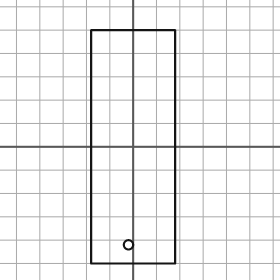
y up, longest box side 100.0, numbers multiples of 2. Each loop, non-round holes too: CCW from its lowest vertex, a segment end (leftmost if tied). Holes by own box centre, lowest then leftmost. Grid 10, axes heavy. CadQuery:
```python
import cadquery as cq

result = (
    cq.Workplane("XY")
    .moveTo(-18.0, -50.0)
    .lineTo(18.0, -50.0)
    .lineTo(18.0, 50.0)
    .lineTo(-18.0, 50.0)
    .close()
    .moveTo(-2.0, -42.0)
    .circle(2.0)
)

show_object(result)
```